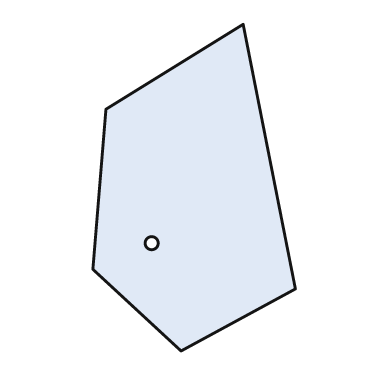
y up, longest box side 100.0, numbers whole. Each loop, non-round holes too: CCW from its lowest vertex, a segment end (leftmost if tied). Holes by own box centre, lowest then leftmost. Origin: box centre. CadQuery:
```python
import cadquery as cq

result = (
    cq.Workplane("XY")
    .moveTo(-4.0, -50.0)
    .lineTo(31.0, -31.0)
    .lineTo(15.0, 50.0)
    .lineTo(-27.0, 24.0)
    .lineTo(-31.0, -25.0)
    .close()
    .moveTo(-13.0, -17.0)
    .circle(2.0)
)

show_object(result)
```